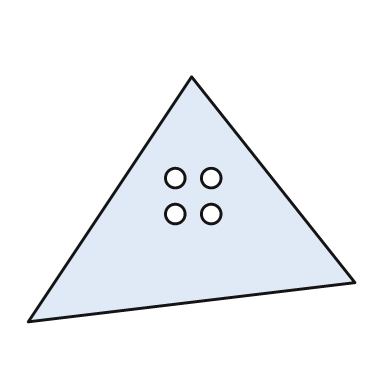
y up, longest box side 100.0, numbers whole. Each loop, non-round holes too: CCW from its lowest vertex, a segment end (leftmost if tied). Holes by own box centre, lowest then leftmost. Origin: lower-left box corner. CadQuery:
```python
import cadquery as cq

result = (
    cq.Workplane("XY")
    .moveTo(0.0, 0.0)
    .lineTo(100.0, 12.0)
    .lineTo(50.0, 75.0)
    .close()
    .moveTo(45.0, 33.0)
    .circle(3.0)
    .moveTo(56.0, 33.0)
    .circle(3.0)
    .moveTo(45.0, 44.0)
    .circle(3.0)
    .moveTo(56.0, 44.0)
    .circle(3.0)
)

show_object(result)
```